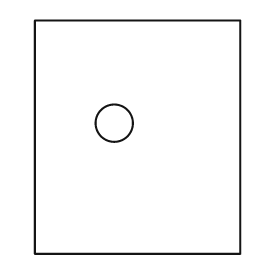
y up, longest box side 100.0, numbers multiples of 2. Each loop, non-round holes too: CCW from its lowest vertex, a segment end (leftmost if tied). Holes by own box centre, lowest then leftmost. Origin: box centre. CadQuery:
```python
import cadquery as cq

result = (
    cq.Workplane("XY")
    .moveTo(-44.0, -50.0)
    .lineTo(44.0, -50.0)
    .lineTo(44.0, 50.0)
    .lineTo(-44.0, 50.0)
    .close()
    .moveTo(-10.0, 6.0)
    .circle(8.0)
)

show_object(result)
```